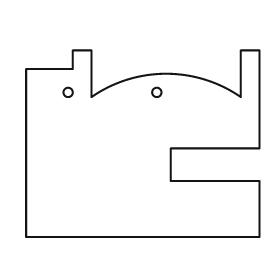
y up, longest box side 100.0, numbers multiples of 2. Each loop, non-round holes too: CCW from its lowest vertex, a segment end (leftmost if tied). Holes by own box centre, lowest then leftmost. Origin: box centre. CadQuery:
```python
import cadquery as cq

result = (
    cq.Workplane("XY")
    .moveTo(-50.0, -40.0)
    .lineTo(50.0, -40.0)
    .lineTo(50.0, -16.0)
    .lineTo(12.0, -16.0)
    .lineTo(12.0, -2.0)
    .lineTo(50.0, -2.0)
    .lineTo(50.0, 40.0)
    .lineTo(42.0, 40.0)
    .lineTo(42.0, 20.0)
    .threePointArc((10.0, 30.0), (-22.0, 20.0))
    .lineTo(-22.0, 40.0)
    .lineTo(-30.0, 40.0)
    .lineTo(-30.0, 32.0)
    .lineTo(-50.0, 32.0)
    .close()
    .moveTo(-32.0, 22.0)
    .circle(2.0)
    .moveTo(6.0, 22.0)
    .circle(2.0)
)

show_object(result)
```